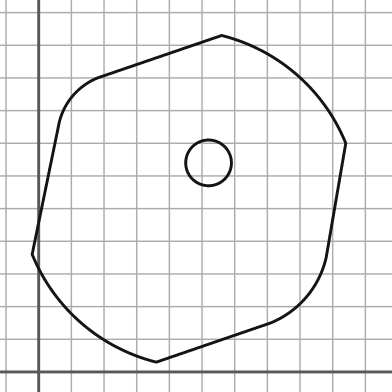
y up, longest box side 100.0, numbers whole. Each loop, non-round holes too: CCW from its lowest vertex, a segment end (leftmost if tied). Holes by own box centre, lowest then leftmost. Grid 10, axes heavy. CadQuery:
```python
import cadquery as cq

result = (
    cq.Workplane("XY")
    .moveTo(36.0, 3.0)
    .lineTo(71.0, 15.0)
    .threePointArc((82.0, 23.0), (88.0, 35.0))
    .lineTo(94.0, 70.0)
    .threePointArc((79.0, 91.0), (56.0, 103.0))
    .lineTo(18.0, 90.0)
    .threePointArc((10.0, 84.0), (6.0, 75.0))
    .lineTo(-2.0, 36.0)
    .threePointArc((13.0, 15.0), (36.0, 3.0))
    .close()
    .moveTo(52.0, 64.0)
    .circle(7.0)
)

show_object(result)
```